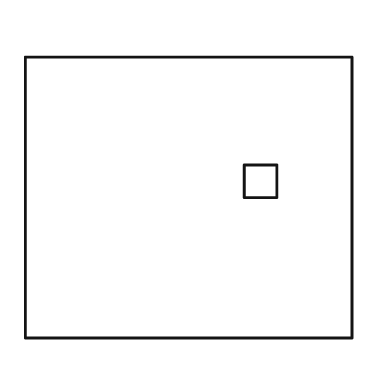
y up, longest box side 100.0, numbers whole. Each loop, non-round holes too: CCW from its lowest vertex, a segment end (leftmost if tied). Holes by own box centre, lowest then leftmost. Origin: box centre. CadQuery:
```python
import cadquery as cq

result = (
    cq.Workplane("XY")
    .moveTo(-50.0, -43.0)
    .lineTo(50.0, -43.0)
    .lineTo(50.0, 43.0)
    .lineTo(-50.0, 43.0)
    .close()
    .moveTo(17.0, 0.0)
    .lineTo(27.0, 0.0)
    .lineTo(27.0, 10.0)
    .lineTo(17.0, 10.0)
    .close()
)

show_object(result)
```